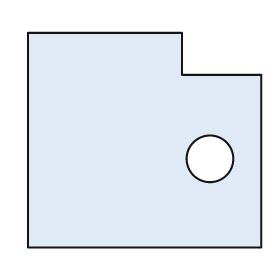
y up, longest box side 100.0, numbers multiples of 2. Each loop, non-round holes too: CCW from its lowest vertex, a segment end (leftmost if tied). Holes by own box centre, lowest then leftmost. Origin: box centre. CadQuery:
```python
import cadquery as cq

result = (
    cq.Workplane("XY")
    .moveTo(-50.0, -46.0)
    .lineTo(50.0, -46.0)
    .lineTo(50.0, 28.0)
    .lineTo(16.0, 28.0)
    .lineTo(16.0, 46.0)
    .lineTo(-50.0, 46.0)
    .close()
    .moveTo(28.0, -8.0)
    .circle(10.0)
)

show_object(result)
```